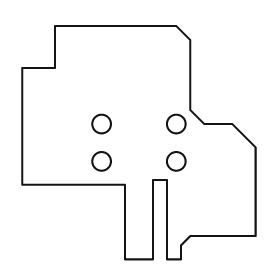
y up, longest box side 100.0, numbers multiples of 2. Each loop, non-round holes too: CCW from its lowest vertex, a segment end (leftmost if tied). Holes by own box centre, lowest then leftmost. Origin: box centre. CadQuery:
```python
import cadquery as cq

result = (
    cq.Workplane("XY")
    .moveTo(-6.0, -50.0)
    .lineTo(6.0, -50.0)
    .lineTo(6.0, -16.0)
    .lineTo(12.0, -16.0)
    .lineTo(12.0, -50.0)
    .lineTo(18.0, -50.0)
    .lineTo(18.0, -44.0)
    .lineTo(22.0, -40.0)
    .lineTo(50.0, -40.0)
    .lineTo(50.0, -2.0)
    .lineTo(40.0, 8.0)
    .lineTo(28.0, 8.0)
    .lineTo(22.0, 14.0)
    .lineTo(22.0, 44.0)
    .lineTo(16.0, 50.0)
    .lineTo(-36.0, 50.0)
    .lineTo(-36.0, 32.0)
    .lineTo(-50.0, 32.0)
    .lineTo(-50.0, -18.0)
    .lineTo(-6.0, -18.0)
    .close()
    .moveTo(-16.0, -8.0)
    .circle(4.0)
    .moveTo(16.0, -8.0)
    .circle(4.0)
    .moveTo(-16.0, 8.0)
    .circle(4.0)
    .moveTo(16.0, 8.0)
    .circle(4.0)
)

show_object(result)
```